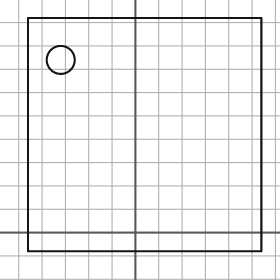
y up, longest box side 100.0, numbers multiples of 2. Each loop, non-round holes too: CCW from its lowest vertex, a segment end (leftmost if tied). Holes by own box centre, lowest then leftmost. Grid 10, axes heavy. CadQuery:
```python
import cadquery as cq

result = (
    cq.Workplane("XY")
    .moveTo(-46.0, -8.0)
    .lineTo(54.0, -8.0)
    .lineTo(54.0, 92.0)
    .lineTo(-46.0, 92.0)
    .close()
    .moveTo(-32.0, 74.0)
    .circle(6.0)
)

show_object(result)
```